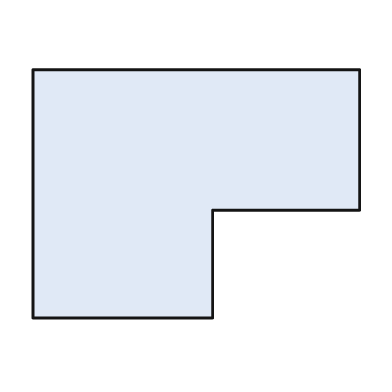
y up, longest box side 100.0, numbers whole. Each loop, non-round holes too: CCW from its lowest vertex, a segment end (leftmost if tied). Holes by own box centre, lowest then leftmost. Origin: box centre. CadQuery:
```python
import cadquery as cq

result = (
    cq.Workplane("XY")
    .moveTo(-50.0, -38.0)
    .lineTo(5.0, -38.0)
    .lineTo(5.0, -5.0)
    .lineTo(50.0, -5.0)
    .lineTo(50.0, 38.0)
    .lineTo(-50.0, 38.0)
    .close()
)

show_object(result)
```